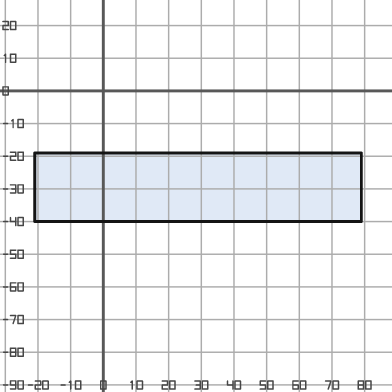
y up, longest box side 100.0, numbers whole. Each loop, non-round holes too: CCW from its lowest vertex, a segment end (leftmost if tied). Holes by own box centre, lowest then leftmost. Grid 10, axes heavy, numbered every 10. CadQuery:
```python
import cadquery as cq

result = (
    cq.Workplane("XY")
    .moveTo(-21.0, -40.0)
    .lineTo(79.0, -40.0)
    .lineTo(79.0, -19.0)
    .lineTo(-21.0, -19.0)
    .close()
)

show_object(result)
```